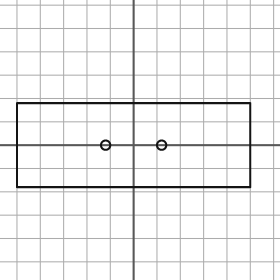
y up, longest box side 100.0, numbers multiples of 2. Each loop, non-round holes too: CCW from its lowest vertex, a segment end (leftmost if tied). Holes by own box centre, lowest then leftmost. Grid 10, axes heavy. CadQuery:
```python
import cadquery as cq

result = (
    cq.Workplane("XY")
    .moveTo(-50.0, -18.0)
    .lineTo(50.0, -18.0)
    .lineTo(50.0, 18.0)
    .lineTo(-50.0, 18.0)
    .close()
    .moveTo(-12.0, 0.0)
    .circle(2.0)
    .moveTo(12.0, 0.0)
    .circle(2.0)
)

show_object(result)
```